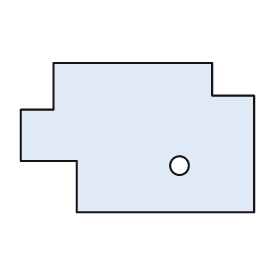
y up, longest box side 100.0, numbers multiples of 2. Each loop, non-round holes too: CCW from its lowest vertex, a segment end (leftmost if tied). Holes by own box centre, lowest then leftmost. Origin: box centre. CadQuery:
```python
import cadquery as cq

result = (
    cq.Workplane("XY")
    .moveTo(-26.0, -32.0)
    .lineTo(50.0, -32.0)
    .lineTo(50.0, 18.0)
    .lineTo(32.0, 18.0)
    .lineTo(32.0, 32.0)
    .lineTo(-36.0, 32.0)
    .lineTo(-36.0, 12.0)
    .lineTo(-50.0, 12.0)
    .lineTo(-50.0, -10.0)
    .lineTo(-26.0, -10.0)
    .close()
    .moveTo(18.0, -12.0)
    .circle(4.0)
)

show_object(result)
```